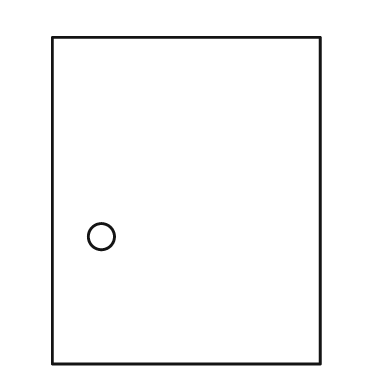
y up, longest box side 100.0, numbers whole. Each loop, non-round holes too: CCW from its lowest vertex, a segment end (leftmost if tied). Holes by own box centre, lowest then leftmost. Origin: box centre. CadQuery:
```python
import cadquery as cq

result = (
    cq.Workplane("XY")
    .moveTo(-41.0, -50.0)
    .lineTo(41.0, -50.0)
    .lineTo(41.0, 50.0)
    .lineTo(-41.0, 50.0)
    .close()
    .moveTo(-26.0, -11.0)
    .circle(4.0)
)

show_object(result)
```